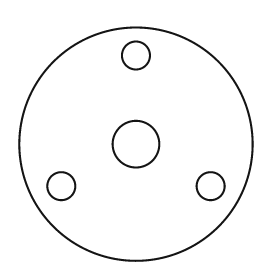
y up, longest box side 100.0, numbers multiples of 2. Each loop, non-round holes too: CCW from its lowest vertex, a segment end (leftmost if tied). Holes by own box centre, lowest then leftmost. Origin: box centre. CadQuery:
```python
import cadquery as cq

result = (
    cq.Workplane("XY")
    .moveTo(0.0, 0.0)
    .circle(50.0)
    .moveTo(-32.0, -18.0)
    .circle(6.0)
    .moveTo(32.0, -18.0)
    .circle(6.0)
    .moveTo(0.0, 0.0)
    .circle(10.0)
    .moveTo(0.0, 38.0)
    .circle(6.0)
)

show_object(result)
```